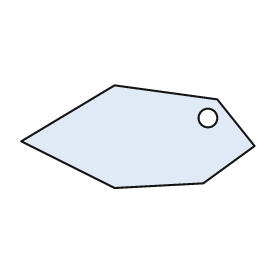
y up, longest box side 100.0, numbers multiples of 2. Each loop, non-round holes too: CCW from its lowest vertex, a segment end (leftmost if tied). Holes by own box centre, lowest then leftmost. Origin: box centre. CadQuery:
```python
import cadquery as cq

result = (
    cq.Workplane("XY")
    .moveTo(-10.0, -22.0)
    .lineTo(28.0, -20.0)
    .lineTo(50.0, -4.0)
    .lineTo(34.0, 16.0)
    .lineTo(-10.0, 22.0)
    .lineTo(-50.0, -2.0)
    .close()
    .moveTo(30.0, 8.0)
    .circle(4.0)
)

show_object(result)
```